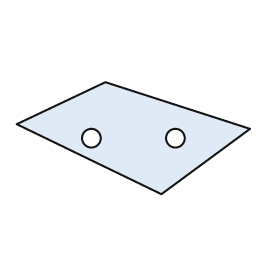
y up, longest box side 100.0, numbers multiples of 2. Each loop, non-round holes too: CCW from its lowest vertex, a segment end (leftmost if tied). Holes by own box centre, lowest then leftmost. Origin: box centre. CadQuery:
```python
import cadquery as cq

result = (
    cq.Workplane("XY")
    .moveTo(12.0, -24.0)
    .lineTo(50.0, 4.0)
    .lineTo(-12.0, 24.0)
    .lineTo(-50.0, 6.0)
    .close()
    .moveTo(-18.0, 0.0)
    .circle(4.0)
    .moveTo(18.0, 0.0)
    .circle(4.0)
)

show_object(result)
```